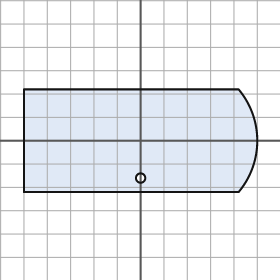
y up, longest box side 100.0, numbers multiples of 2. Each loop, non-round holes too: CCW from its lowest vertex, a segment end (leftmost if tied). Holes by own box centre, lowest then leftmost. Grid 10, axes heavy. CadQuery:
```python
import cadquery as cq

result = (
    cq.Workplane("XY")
    .moveTo(-50.0, -22.0)
    .lineTo(42.0, -22.0)
    .threePointArc((50.0, 0.0), (42.0, 22.0))
    .lineTo(-50.0, 22.0)
    .close()
    .moveTo(0.0, -16.0)
    .circle(2.0)
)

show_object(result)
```